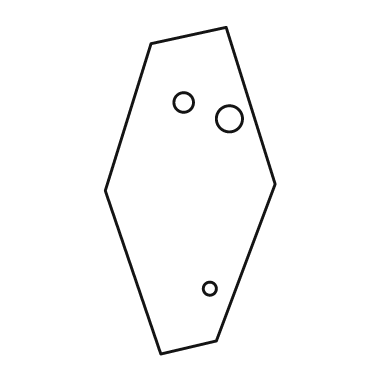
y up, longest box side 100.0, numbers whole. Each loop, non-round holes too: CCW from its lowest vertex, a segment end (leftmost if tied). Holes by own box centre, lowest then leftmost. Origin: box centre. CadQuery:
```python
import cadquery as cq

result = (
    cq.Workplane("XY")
    .moveTo(-9.0, -50.0)
    .lineTo(8.0, -46.0)
    .lineTo(26.0, 2.0)
    .lineTo(11.0, 50.0)
    .lineTo(-12.0, 45.0)
    .lineTo(-26.0, 0.0)
    .close()
    .moveTo(6.0, -30.0)
    .circle(2.0)
    .moveTo(12.0, 22.0)
    .circle(4.0)
    .moveTo(-2.0, 27.0)
    .circle(3.0)
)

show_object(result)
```